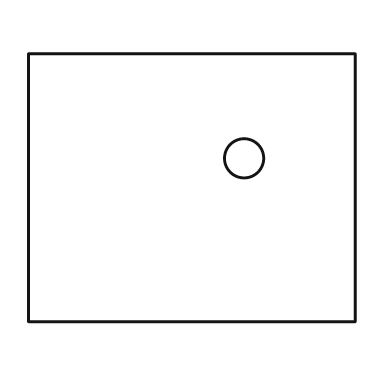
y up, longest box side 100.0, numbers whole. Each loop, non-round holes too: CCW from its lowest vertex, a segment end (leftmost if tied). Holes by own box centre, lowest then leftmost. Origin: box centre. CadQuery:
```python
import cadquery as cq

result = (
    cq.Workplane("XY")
    .moveTo(-50.0, -41.0)
    .lineTo(50.0, -41.0)
    .lineTo(50.0, 41.0)
    .lineTo(-50.0, 41.0)
    .close()
    .moveTo(16.0, 9.0)
    .circle(6.0)
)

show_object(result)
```